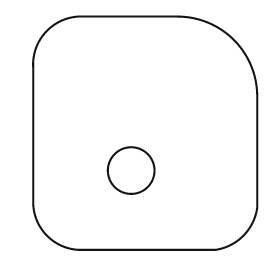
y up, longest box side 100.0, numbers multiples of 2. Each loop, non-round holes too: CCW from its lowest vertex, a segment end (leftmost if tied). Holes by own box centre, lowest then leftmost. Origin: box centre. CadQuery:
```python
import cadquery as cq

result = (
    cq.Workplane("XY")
    .moveTo(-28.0, -50.0)
    .lineTo(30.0, -50.0)
    .threePointArc((42.0, -44.0), (48.0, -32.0))
    .lineTo(48.0, 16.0)
    .threePointArc((38.0, 40.0), (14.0, 50.0))
    .lineTo(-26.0, 50.0)
    .threePointArc((-42.0, 44.0), (-48.0, 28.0))
    .lineTo(-48.0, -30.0)
    .threePointArc((-42.0, -44.0), (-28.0, -50.0))
    .close()
    .moveTo(-6.0, -16.0)
    .circle(10.0)
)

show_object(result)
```